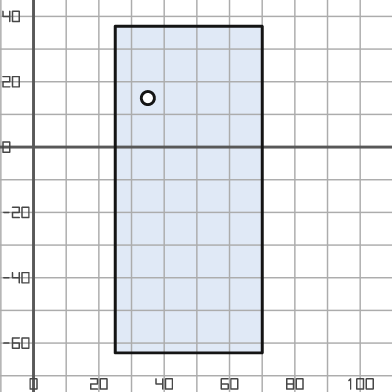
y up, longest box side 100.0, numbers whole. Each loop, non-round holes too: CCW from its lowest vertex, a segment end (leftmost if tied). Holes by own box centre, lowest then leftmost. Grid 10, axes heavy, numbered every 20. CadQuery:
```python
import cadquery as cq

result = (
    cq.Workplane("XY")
    .moveTo(25.0, -63.0)
    .lineTo(70.0, -63.0)
    .lineTo(70.0, 37.0)
    .lineTo(25.0, 37.0)
    .close()
    .moveTo(35.0, 15.0)
    .circle(2.0)
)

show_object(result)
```